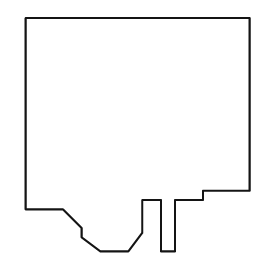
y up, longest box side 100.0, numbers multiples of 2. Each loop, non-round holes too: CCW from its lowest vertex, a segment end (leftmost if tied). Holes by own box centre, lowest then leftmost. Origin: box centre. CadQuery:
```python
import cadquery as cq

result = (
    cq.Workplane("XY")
    .moveTo(-16.0, -50.0)
    .lineTo(-4.0, -50.0)
    .lineTo(2.0, -42.0)
    .lineTo(2.0, -28.0)
    .lineTo(10.0, -28.0)
    .lineTo(10.0, -50.0)
    .lineTo(16.0, -50.0)
    .lineTo(16.0, -28.0)
    .lineTo(28.0, -28.0)
    .lineTo(28.0, -24.0)
    .lineTo(48.0, -24.0)
    .lineTo(48.0, 50.0)
    .lineTo(-48.0, 50.0)
    .lineTo(-48.0, -32.0)
    .lineTo(-32.0, -32.0)
    .lineTo(-24.0, -40.0)
    .lineTo(-24.0, -44.0)
    .close()
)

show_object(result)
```